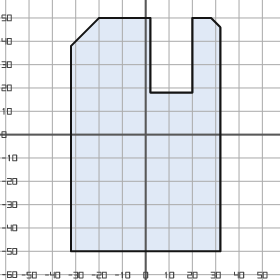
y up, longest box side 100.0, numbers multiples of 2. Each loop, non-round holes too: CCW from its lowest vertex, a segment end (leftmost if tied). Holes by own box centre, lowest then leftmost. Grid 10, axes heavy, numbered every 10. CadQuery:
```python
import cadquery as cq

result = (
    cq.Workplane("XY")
    .moveTo(-32.0, -50.0)
    .lineTo(32.0, -50.0)
    .lineTo(32.0, 46.0)
    .lineTo(28.0, 50.0)
    .lineTo(20.0, 50.0)
    .lineTo(20.0, 18.0)
    .lineTo(2.0, 18.0)
    .lineTo(2.0, 50.0)
    .lineTo(-20.0, 50.0)
    .lineTo(-32.0, 38.0)
    .close()
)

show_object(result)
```